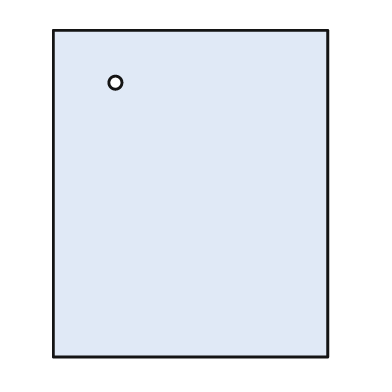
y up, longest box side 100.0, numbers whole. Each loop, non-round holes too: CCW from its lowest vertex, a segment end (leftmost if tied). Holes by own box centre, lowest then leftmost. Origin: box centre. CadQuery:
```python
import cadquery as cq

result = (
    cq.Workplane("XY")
    .moveTo(-42.0, -50.0)
    .lineTo(42.0, -50.0)
    .lineTo(42.0, 50.0)
    .lineTo(-42.0, 50.0)
    .close()
    .moveTo(-23.0, 34.0)
    .circle(2.0)
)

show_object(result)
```